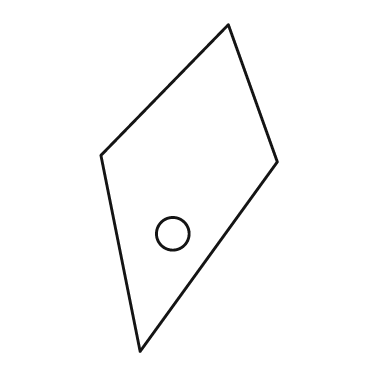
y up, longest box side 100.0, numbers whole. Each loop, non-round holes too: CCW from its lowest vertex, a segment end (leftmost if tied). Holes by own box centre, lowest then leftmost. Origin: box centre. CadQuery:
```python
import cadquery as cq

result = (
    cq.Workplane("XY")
    .moveTo(-15.0, -50.0)
    .lineTo(27.0, 8.0)
    .lineTo(12.0, 50.0)
    .lineTo(-27.0, 10.0)
    .close()
    .moveTo(-5.0, -14.0)
    .circle(5.0)
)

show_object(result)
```